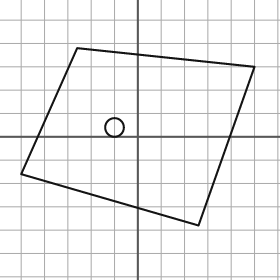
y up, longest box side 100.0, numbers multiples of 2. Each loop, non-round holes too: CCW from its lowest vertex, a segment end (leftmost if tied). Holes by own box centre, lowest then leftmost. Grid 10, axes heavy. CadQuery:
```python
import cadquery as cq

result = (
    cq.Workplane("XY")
    .moveTo(26.0, -38.0)
    .lineTo(50.0, 30.0)
    .lineTo(-26.0, 38.0)
    .lineTo(-50.0, -16.0)
    .close()
    .moveTo(-10.0, 4.0)
    .circle(4.0)
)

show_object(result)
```